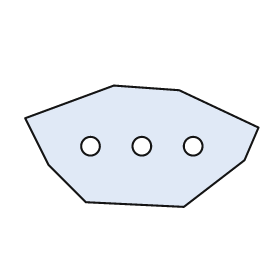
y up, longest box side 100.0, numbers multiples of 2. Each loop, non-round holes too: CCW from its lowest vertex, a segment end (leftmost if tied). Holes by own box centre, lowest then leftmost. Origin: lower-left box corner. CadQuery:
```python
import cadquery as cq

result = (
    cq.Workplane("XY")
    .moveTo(68.0, 0.0)
    .lineTo(94.0, 20.0)
    .lineTo(100.0, 34.0)
    .lineTo(66.0, 50.0)
    .lineTo(38.0, 52.0)
    .lineTo(0.0, 38.0)
    .lineTo(10.0, 18.0)
    .lineTo(26.0, 2.0)
    .close()
    .moveTo(28.0, 26.0)
    .circle(4.0)
    .moveTo(50.0, 26.0)
    .circle(4.0)
    .moveTo(72.0, 26.0)
    .circle(4.0)
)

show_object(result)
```